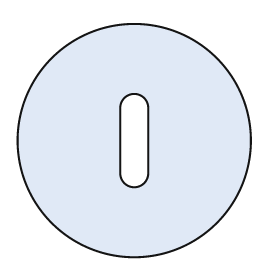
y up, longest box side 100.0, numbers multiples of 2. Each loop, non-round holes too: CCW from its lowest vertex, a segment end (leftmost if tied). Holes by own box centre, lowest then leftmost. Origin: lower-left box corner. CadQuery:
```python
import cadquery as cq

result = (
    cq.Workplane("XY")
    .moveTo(50.0, 50.0)
    .circle(50.0)
    .moveTo(44.0, 36.0)
    .threePointArc((50.0, 30.0), (56.0, 36.0))
    .lineTo(56.0, 64.0)
    .threePointArc((50.0, 70.0), (44.0, 64.0))
    .close()
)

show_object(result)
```